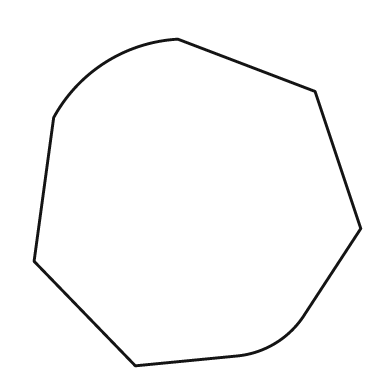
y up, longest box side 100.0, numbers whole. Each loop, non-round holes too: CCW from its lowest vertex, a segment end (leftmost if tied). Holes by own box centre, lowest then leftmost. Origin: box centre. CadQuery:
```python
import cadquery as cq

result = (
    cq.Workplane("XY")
    .moveTo(-19.0, -50.0)
    .lineTo(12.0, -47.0)
    .threePointArc((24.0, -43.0), (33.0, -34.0))
    .lineTo(50.0, -8.0)
    .lineTo(36.0, 34.0)
    .lineTo(-6.0, 50.0)
    .threePointArc((-28.0, 43.0), (-44.0, 26.0))
    .lineTo(-50.0, -18.0)
    .close()
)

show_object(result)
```